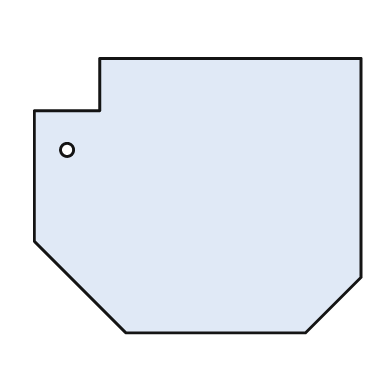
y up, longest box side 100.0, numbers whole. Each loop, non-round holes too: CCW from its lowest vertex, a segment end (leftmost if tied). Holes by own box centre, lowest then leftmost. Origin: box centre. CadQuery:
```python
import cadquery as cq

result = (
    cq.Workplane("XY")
    .moveTo(-22.0, -42.0)
    .lineTo(33.0, -42.0)
    .lineTo(50.0, -25.0)
    .lineTo(50.0, 42.0)
    .lineTo(-30.0, 42.0)
    .lineTo(-30.0, 26.0)
    .lineTo(-50.0, 26.0)
    .lineTo(-50.0, -14.0)
    .close()
    .moveTo(-40.0, 14.0)
    .circle(2.0)
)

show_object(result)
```